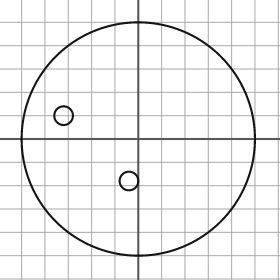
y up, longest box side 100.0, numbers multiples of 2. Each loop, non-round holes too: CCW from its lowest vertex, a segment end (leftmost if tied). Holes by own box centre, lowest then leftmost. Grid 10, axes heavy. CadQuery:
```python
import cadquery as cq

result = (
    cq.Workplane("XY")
    .moveTo(0.0, 0.0)
    .circle(50.0)
    .moveTo(-4.0, -18.0)
    .circle(4.0)
    .moveTo(-32.0, 10.0)
    .circle(4.0)
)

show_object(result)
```